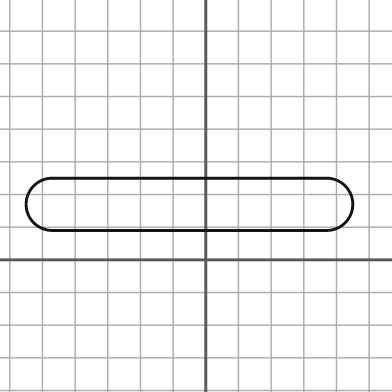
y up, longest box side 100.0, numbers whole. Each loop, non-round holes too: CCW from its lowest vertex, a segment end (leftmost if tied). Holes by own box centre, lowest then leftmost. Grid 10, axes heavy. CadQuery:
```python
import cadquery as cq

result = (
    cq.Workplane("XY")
    .moveTo(-47.0, 9.0)
    .lineTo(37.0, 9.0)
    .threePointArc((45.0, 17.0), (37.0, 25.0))
    .lineTo(-47.0, 25.0)
    .threePointArc((-55.0, 17.0), (-47.0, 9.0))
    .close()
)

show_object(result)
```